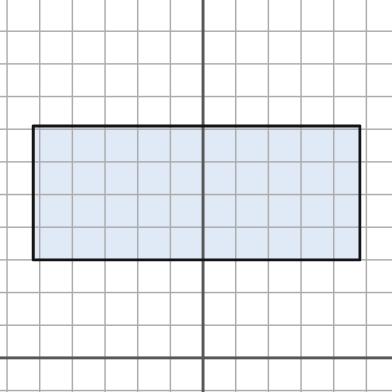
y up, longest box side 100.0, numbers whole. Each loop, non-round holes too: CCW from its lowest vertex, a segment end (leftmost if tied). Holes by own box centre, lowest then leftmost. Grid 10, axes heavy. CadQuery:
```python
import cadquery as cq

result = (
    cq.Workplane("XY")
    .moveTo(-52.0, 30.0)
    .lineTo(48.0, 30.0)
    .lineTo(48.0, 71.0)
    .lineTo(-52.0, 71.0)
    .close()
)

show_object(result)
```